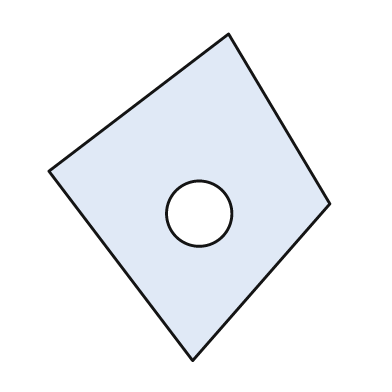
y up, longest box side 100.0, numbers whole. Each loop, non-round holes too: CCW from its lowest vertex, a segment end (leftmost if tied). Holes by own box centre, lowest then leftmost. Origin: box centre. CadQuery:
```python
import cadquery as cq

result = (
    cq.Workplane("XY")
    .moveTo(1.0, -50.0)
    .lineTo(43.0, -2.0)
    .lineTo(12.0, 50.0)
    .lineTo(-43.0, 8.0)
    .close()
    .moveTo(3.0, -5.0)
    .circle(10.0)
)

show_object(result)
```